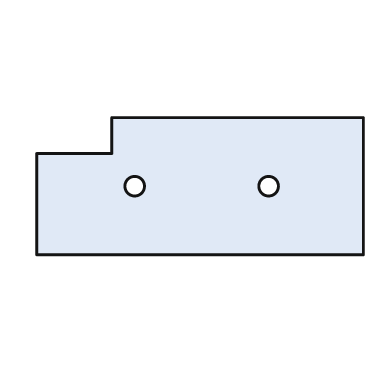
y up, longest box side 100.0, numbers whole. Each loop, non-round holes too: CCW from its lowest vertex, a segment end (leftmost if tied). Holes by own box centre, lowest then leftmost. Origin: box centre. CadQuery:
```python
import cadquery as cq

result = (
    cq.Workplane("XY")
    .moveTo(-50.0, -21.0)
    .lineTo(50.0, -21.0)
    .lineTo(50.0, 21.0)
    .lineTo(-27.0, 21.0)
    .lineTo(-27.0, 10.0)
    .lineTo(-50.0, 10.0)
    .close()
    .moveTo(-20.0, 0.0)
    .circle(3.0)
    .moveTo(21.0, 0.0)
    .circle(3.0)
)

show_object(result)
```